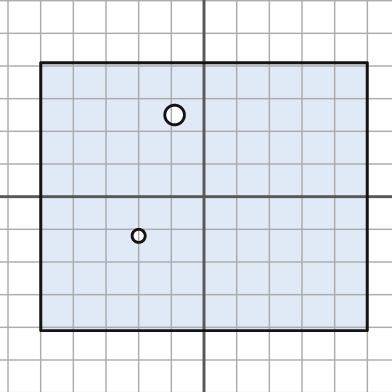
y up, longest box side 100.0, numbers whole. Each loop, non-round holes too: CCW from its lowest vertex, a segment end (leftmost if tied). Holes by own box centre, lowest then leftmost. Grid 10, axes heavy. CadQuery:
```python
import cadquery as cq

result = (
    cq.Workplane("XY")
    .moveTo(-50.0, -41.0)
    .lineTo(50.0, -41.0)
    .lineTo(50.0, 41.0)
    .lineTo(-50.0, 41.0)
    .close()
    .moveTo(-20.0, -12.0)
    .circle(2.0)
    .moveTo(-9.0, 25.0)
    .circle(3.0)
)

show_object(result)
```